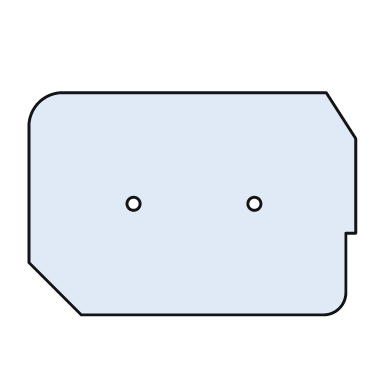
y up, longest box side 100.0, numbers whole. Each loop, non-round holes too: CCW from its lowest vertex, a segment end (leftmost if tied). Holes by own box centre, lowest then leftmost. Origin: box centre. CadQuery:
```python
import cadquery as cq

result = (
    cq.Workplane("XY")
    .moveTo(-34.0, -34.0)
    .lineTo(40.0, -34.0)
    .threePointArc((45.0, -32.0), (47.0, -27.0))
    .lineTo(47.0, -9.0)
    .lineTo(50.0, -9.0)
    .lineTo(50.0, 20.0)
    .lineTo(41.0, 34.0)
    .lineTo(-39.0, 34.0)
    .threePointArc((-47.0, 31.0), (-50.0, 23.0))
    .lineTo(-50.0, -18.0)
    .close()
    .moveTo(-18.0, 0.0)
    .circle(2.0)
    .moveTo(19.0, 0.0)
    .circle(2.0)
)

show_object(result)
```